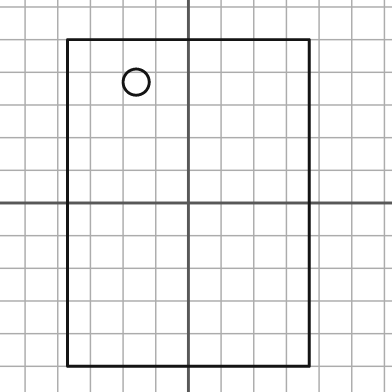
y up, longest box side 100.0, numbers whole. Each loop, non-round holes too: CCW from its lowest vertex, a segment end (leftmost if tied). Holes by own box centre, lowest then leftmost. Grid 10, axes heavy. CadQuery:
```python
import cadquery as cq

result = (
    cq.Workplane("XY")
    .moveTo(-37.0, -50.0)
    .lineTo(37.0, -50.0)
    .lineTo(37.0, 50.0)
    .lineTo(-37.0, 50.0)
    .close()
    .moveTo(-16.0, 37.0)
    .circle(4.0)
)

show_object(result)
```